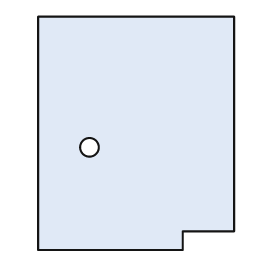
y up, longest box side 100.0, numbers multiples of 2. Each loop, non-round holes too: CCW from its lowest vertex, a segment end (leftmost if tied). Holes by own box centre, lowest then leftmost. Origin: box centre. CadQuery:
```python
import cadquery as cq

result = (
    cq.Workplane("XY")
    .moveTo(-42.0, -50.0)
    .lineTo(20.0, -50.0)
    .lineTo(20.0, -42.0)
    .lineTo(42.0, -42.0)
    .lineTo(42.0, 50.0)
    .lineTo(-42.0, 50.0)
    .close()
    .moveTo(-20.0, -6.0)
    .circle(4.0)
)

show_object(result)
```